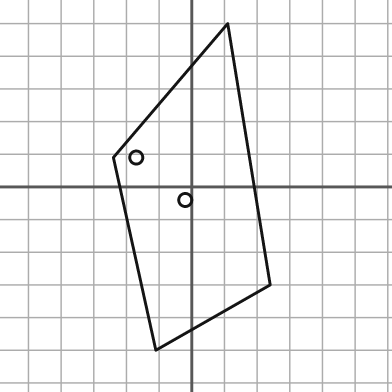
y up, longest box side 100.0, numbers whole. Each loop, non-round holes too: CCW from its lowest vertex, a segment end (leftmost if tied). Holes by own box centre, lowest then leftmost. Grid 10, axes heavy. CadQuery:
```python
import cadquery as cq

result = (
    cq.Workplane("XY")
    .moveTo(-11.0, -50.0)
    .lineTo(24.0, -30.0)
    .lineTo(11.0, 50.0)
    .lineTo(-24.0, 9.0)
    .close()
    .moveTo(-2.0, -4.0)
    .circle(2.0)
    .moveTo(-17.0, 9.0)
    .circle(2.0)
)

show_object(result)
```